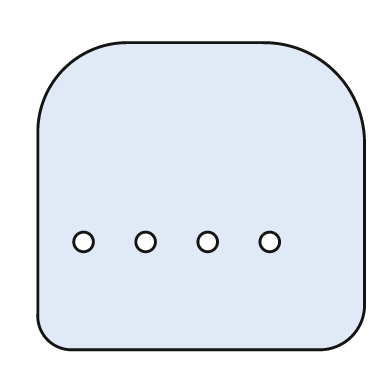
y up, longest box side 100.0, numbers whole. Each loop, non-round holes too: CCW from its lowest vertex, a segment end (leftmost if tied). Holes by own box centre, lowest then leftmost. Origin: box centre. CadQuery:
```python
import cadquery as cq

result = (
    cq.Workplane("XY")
    .moveTo(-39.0, -47.0)
    .lineTo(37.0, -47.0)
    .threePointArc((46.0, -43.0), (50.0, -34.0))
    .lineTo(50.0, 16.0)
    .threePointArc((41.0, 38.0), (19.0, 47.0))
    .lineTo(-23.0, 47.0)
    .threePointArc((-42.0, 39.0), (-50.0, 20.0))
    .lineTo(-50.0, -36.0)
    .threePointArc((-47.0, -44.0), (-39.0, -47.0))
    .close()
    .moveTo(-36.0, -14.0)
    .circle(3.0)
    .moveTo(-17.0, -14.0)
    .circle(3.0)
    .moveTo(2.0, -14.0)
    .circle(3.0)
    .moveTo(21.0, -14.0)
    .circle(3.0)
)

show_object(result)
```